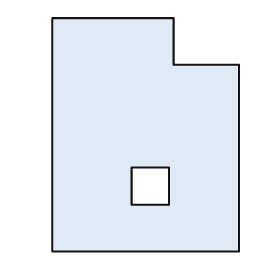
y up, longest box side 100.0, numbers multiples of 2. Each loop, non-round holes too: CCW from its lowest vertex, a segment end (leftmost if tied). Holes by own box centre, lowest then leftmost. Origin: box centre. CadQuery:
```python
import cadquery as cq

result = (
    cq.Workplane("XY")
    .moveTo(-40.0, -50.0)
    .lineTo(40.0, -50.0)
    .lineTo(40.0, 30.0)
    .lineTo(12.0, 30.0)
    .lineTo(12.0, 50.0)
    .lineTo(-40.0, 50.0)
    .close()
    .moveTo(-6.0, -30.0)
    .lineTo(10.0, -30.0)
    .lineTo(10.0, -14.0)
    .lineTo(-6.0, -14.0)
    .close()
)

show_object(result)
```